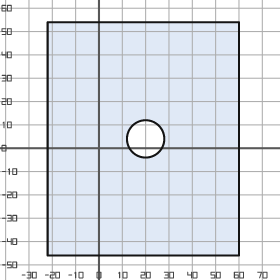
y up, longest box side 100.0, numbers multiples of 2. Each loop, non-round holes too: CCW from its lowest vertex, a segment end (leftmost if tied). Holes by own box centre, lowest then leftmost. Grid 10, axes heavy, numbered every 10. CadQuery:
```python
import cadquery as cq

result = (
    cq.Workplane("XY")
    .moveTo(-22.0, -46.0)
    .lineTo(60.0, -46.0)
    .lineTo(60.0, 54.0)
    .lineTo(-22.0, 54.0)
    .close()
    .moveTo(20.0, 4.0)
    .circle(8.0)
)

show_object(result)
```